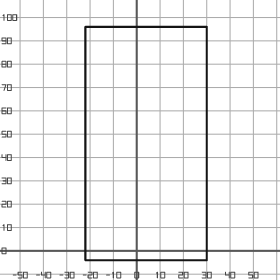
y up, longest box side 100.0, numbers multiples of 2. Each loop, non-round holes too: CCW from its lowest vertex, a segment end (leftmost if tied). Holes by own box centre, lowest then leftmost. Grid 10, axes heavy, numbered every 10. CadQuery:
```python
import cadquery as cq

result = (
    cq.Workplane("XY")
    .moveTo(-22.0, -4.0)
    .lineTo(30.0, -4.0)
    .lineTo(30.0, 96.0)
    .lineTo(-22.0, 96.0)
    .close()
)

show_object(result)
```